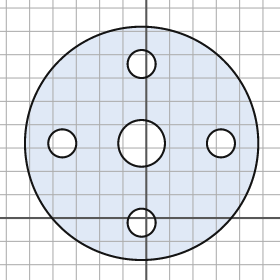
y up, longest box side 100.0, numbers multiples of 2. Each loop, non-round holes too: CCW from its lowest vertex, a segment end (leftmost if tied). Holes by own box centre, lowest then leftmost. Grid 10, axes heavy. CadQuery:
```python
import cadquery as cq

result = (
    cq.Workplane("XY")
    .moveTo(-2.0, 32.0)
    .circle(50.0)
    .moveTo(-2.0, -2.0)
    .circle(6.0)
    .moveTo(-36.0, 32.0)
    .circle(6.0)
    .moveTo(-2.0, 32.0)
    .circle(10.0)
    .moveTo(32.0, 32.0)
    .circle(6.0)
    .moveTo(-2.0, 66.0)
    .circle(6.0)
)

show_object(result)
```